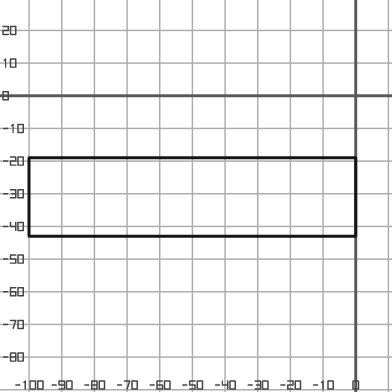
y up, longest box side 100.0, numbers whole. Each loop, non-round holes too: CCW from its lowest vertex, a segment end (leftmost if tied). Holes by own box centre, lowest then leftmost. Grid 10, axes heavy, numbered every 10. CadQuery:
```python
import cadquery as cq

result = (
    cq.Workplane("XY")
    .moveTo(-100.0, -43.0)
    .lineTo(0.0, -43.0)
    .lineTo(0.0, -19.0)
    .lineTo(-100.0, -19.0)
    .close()
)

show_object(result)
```